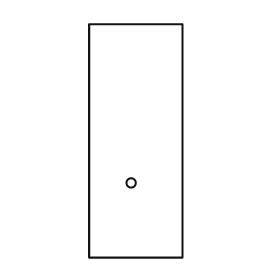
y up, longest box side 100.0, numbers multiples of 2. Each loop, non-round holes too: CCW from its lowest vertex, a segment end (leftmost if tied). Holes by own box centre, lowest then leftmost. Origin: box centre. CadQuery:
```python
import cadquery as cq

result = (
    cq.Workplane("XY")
    .moveTo(-20.0, -50.0)
    .lineTo(20.0, -50.0)
    .lineTo(20.0, 50.0)
    .lineTo(-20.0, 50.0)
    .close()
    .moveTo(-2.0, -18.0)
    .circle(2.0)
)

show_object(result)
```